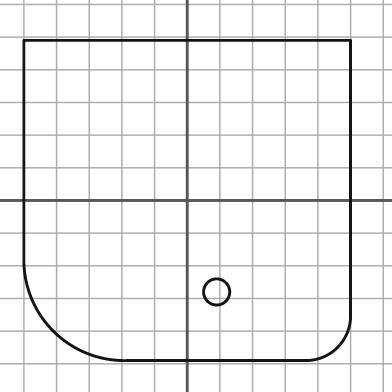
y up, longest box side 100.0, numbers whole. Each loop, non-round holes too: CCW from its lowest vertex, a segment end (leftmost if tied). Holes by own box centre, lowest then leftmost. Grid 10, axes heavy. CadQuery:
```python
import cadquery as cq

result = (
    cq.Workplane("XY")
    .moveTo(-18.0, -49.0)
    .lineTo(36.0, -49.0)
    .threePointArc((46.0, -45.0), (50.0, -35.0))
    .lineTo(50.0, 49.0)
    .lineTo(-50.0, 49.0)
    .lineTo(-50.0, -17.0)
    .threePointArc((-41.0, -40.0), (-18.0, -49.0))
    .close()
    .moveTo(9.0, -28.0)
    .circle(4.0)
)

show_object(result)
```